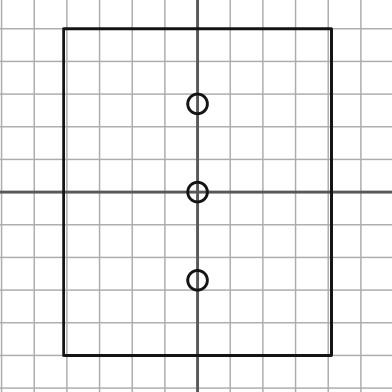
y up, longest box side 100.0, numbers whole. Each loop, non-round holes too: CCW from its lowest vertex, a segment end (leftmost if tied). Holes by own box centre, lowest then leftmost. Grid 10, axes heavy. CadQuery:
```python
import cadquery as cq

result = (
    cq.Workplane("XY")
    .moveTo(-41.0, -50.0)
    .lineTo(41.0, -50.0)
    .lineTo(41.0, 50.0)
    .lineTo(-41.0, 50.0)
    .close()
    .moveTo(0.0, -27.0)
    .circle(3.0)
    .moveTo(0.0, 0.0)
    .circle(3.0)
    .moveTo(0.0, 27.0)
    .circle(3.0)
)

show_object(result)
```